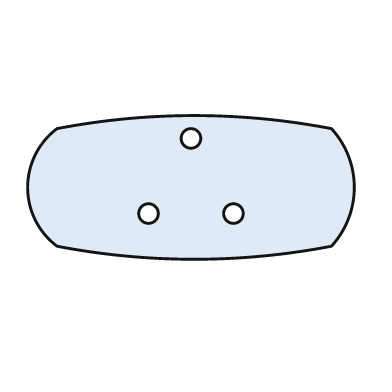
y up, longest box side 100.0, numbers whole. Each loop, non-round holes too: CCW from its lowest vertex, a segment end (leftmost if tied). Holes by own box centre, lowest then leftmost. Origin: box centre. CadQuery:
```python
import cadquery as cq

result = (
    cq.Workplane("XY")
    .moveTo(-41.0, -18.0)
    .threePointArc((1.0, -22.0), (43.0, -18.0))
    .threePointArc((50.0, 0.0), (43.0, 18.0))
    .threePointArc((1.0, 22.0), (-41.0, 18.0))
    .threePointArc((-50.0, 0.0), (-41.0, -18.0))
    .close()
    .moveTo(-13.0, -8.0)
    .circle(3.0)
    .moveTo(13.0, -8.0)
    .circle(3.0)
    .moveTo(0.0, 15.0)
    .circle(3.0)
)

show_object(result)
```